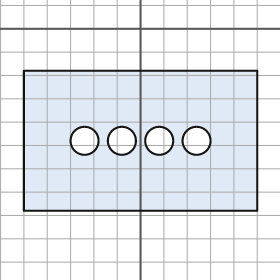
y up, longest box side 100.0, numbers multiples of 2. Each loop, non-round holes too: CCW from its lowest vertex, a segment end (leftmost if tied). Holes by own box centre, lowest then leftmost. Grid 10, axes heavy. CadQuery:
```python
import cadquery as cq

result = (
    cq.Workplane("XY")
    .moveTo(-50.0, -78.0)
    .lineTo(50.0, -78.0)
    .lineTo(50.0, -18.0)
    .lineTo(-50.0, -18.0)
    .close()
    .moveTo(-24.0, -48.0)
    .circle(6.0)
    .moveTo(-8.0, -48.0)
    .circle(6.0)
    .moveTo(8.0, -48.0)
    .circle(6.0)
    .moveTo(24.0, -48.0)
    .circle(6.0)
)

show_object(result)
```